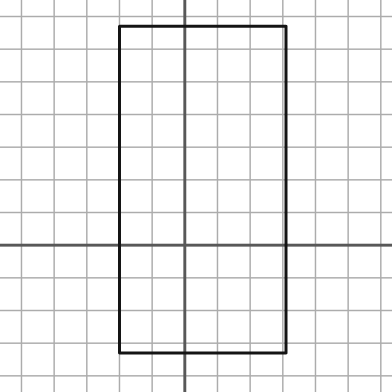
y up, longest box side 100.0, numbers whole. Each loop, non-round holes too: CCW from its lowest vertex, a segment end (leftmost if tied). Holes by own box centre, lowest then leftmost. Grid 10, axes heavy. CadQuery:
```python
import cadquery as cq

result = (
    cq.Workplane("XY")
    .moveTo(-20.0, -33.0)
    .lineTo(31.0, -33.0)
    .lineTo(31.0, 67.0)
    .lineTo(-20.0, 67.0)
    .close()
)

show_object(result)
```